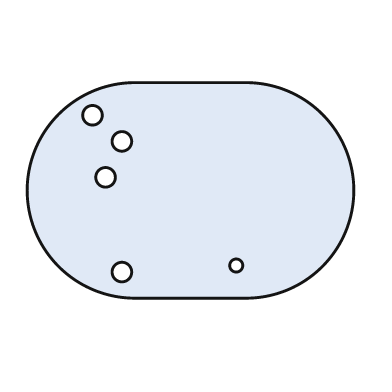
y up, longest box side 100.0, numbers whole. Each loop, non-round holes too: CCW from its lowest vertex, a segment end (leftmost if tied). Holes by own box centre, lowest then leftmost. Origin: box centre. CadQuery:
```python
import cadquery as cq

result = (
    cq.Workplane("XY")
    .moveTo(-17.0, -33.0)
    .lineTo(17.0, -33.0)
    .threePointArc((50.0, 0.0), (17.0, 33.0))
    .lineTo(-17.0, 33.0)
    .threePointArc((-50.0, 0.0), (-17.0, -33.0))
    .close()
    .moveTo(-21.0, -25.0)
    .circle(3.0)
    .moveTo(14.0, -23.0)
    .circle(2.0)
    .moveTo(-26.0, 4.0)
    .circle(3.0)
    .moveTo(-21.0, 15.0)
    .circle(3.0)
    .moveTo(-30.0, 23.0)
    .circle(3.0)
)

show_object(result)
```